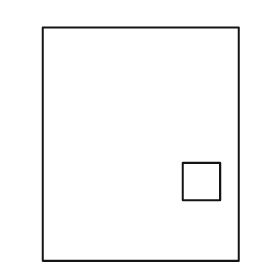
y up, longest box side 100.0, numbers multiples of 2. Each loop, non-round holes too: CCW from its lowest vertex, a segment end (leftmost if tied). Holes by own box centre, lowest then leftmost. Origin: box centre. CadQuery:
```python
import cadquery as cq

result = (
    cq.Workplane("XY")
    .moveTo(-42.0, -50.0)
    .lineTo(42.0, -50.0)
    .lineTo(42.0, 50.0)
    .lineTo(-42.0, 50.0)
    .close()
    .moveTo(18.0, -24.0)
    .lineTo(34.0, -24.0)
    .lineTo(34.0, -8.0)
    .lineTo(18.0, -8.0)
    .close()
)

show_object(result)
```